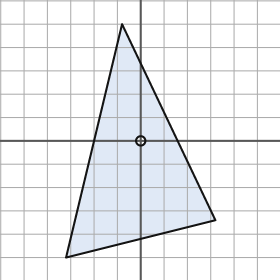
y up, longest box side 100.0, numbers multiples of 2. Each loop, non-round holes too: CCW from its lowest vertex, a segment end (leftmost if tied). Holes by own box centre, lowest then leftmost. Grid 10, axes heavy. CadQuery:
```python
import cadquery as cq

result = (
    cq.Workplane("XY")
    .moveTo(-32.0, -50.0)
    .lineTo(32.0, -34.0)
    .lineTo(-8.0, 50.0)
    .close()
    .moveTo(0.0, 0.0)
    .circle(2.0)
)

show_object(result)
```